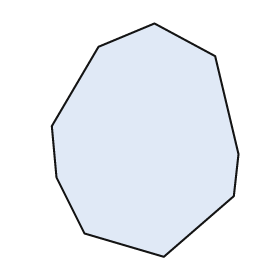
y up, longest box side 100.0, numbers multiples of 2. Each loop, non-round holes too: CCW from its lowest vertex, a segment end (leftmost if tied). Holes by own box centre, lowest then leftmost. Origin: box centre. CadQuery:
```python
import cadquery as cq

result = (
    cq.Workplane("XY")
    .moveTo(8.0, -50.0)
    .lineTo(38.0, -24.0)
    .lineTo(40.0, -6.0)
    .lineTo(30.0, 36.0)
    .lineTo(4.0, 50.0)
    .lineTo(-20.0, 40.0)
    .lineTo(-40.0, 6.0)
    .lineTo(-38.0, -16.0)
    .lineTo(-26.0, -40.0)
    .close()
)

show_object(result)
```